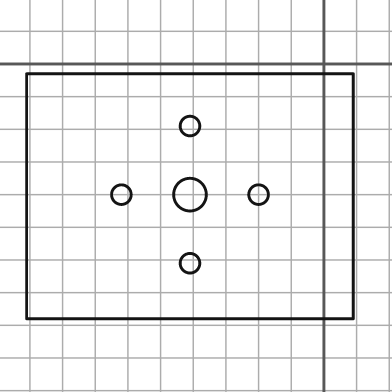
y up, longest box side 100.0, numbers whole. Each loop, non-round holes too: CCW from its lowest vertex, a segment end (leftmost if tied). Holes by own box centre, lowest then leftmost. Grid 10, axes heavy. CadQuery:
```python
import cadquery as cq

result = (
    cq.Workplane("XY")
    .moveTo(-91.0, -78.0)
    .lineTo(9.0, -78.0)
    .lineTo(9.0, -3.0)
    .lineTo(-91.0, -3.0)
    .close()
    .moveTo(-41.0, -61.0)
    .circle(3.0)
    .moveTo(-62.0, -40.0)
    .circle(3.0)
    .moveTo(-41.0, -40.0)
    .circle(5.0)
    .moveTo(-20.0, -40.0)
    .circle(3.0)
    .moveTo(-41.0, -19.0)
    .circle(3.0)
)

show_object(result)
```